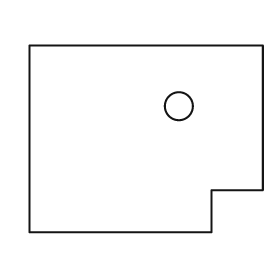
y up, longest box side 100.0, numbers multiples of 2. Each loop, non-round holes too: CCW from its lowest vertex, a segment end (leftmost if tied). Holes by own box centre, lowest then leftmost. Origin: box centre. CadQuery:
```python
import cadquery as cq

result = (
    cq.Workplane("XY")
    .moveTo(-50.0, -40.0)
    .lineTo(28.0, -40.0)
    .lineTo(28.0, -22.0)
    .lineTo(50.0, -22.0)
    .lineTo(50.0, 40.0)
    .lineTo(-50.0, 40.0)
    .close()
    .moveTo(14.0, 14.0)
    .circle(6.0)
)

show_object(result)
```